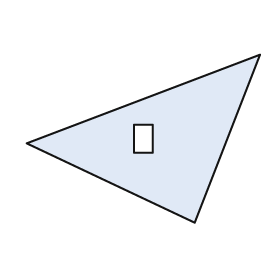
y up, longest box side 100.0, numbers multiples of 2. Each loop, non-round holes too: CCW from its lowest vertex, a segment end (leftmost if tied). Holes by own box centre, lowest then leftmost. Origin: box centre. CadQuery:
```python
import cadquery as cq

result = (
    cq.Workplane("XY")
    .moveTo(22.0, -36.0)
    .lineTo(50.0, 36.0)
    .lineTo(-50.0, -2.0)
    .close()
    .moveTo(-4.0, -6.0)
    .lineTo(4.0, -6.0)
    .lineTo(4.0, 6.0)
    .lineTo(-4.0, 6.0)
    .close()
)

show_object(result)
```